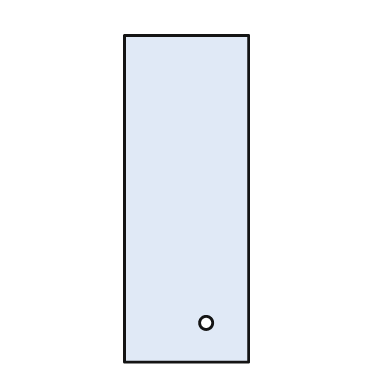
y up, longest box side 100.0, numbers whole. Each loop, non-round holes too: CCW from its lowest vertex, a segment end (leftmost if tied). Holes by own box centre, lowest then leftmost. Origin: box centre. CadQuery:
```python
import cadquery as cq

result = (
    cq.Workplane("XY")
    .moveTo(-19.0, -50.0)
    .lineTo(19.0, -50.0)
    .lineTo(19.0, 50.0)
    .lineTo(-19.0, 50.0)
    .close()
    .moveTo(6.0, -38.0)
    .circle(2.0)
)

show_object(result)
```